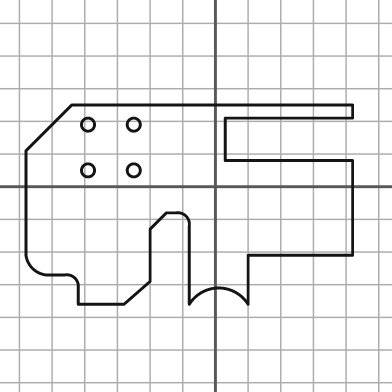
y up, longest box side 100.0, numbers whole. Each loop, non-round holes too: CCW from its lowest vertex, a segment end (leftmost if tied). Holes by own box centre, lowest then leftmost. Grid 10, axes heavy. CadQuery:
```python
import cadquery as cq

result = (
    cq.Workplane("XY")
    .moveTo(-42.0, -36.0)
    .lineTo(-28.0, -36.0)
    .lineTo(-20.0, -29.0)
    .lineTo(-20.0, -13.0)
    .lineTo(-15.0, -8.0)
    .lineTo(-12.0, -8.0)
    .threePointArc((-9.0, -9.0), (-8.0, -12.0))
    .lineTo(-8.0, -36.0)
    .threePointArc((1.0, -31.0), (10.0, -36.0))
    .lineTo(10.0, -21.0)
    .lineTo(42.0, -21.0)
    .lineTo(42.0, 8.0)
    .lineTo(3.0, 8.0)
    .lineTo(3.0, 21.0)
    .lineTo(42.0, 21.0)
    .lineTo(42.0, 25.0)
    .lineTo(-44.0, 25.0)
    .lineTo(-58.0, 11.0)
    .lineTo(-58.0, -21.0)
    .threePointArc((-56.0, -25.0), (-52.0, -27.0))
    .lineTo(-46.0, -27.0)
    .threePointArc((-43.0, -28.0), (-42.0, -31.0))
    .close()
    .moveTo(-39.0, 5.0)
    .circle(2.0)
    .moveTo(-25.0, 5.0)
    .circle(2.0)
    .moveTo(-39.0, 19.0)
    .circle(2.0)
    .moveTo(-25.0, 19.0)
    .circle(2.0)
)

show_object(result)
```